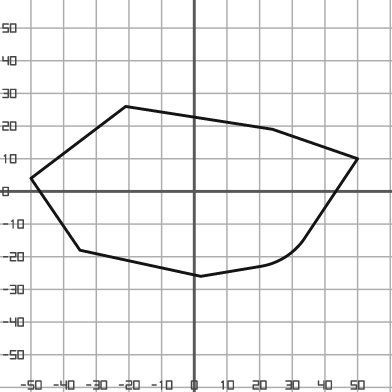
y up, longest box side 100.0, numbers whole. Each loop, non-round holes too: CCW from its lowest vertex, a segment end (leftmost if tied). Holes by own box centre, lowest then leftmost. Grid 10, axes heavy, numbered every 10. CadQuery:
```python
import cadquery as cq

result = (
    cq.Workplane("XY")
    .moveTo(2.0, -26.0)
    .lineTo(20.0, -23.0)
    .threePointArc((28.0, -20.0), (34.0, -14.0))
    .lineTo(50.0, 10.0)
    .lineTo(24.0, 19.0)
    .lineTo(-21.0, 26.0)
    .lineTo(-50.0, 4.0)
    .lineTo(-35.0, -18.0)
    .close()
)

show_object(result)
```